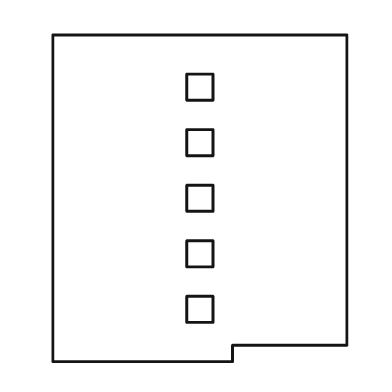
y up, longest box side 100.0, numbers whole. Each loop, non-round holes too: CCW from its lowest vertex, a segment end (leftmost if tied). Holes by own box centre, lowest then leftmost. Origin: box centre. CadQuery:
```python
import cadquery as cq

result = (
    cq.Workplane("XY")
    .moveTo(-45.0, -50.0)
    .lineTo(10.0, -50.0)
    .lineTo(10.0, -45.0)
    .lineTo(45.0, -45.0)
    .lineTo(45.0, 50.0)
    .lineTo(-45.0, 50.0)
    .close()
    .moveTo(-4.0, -38.0)
    .lineTo(4.0, -38.0)
    .lineTo(4.0, -30.0)
    .lineTo(-4.0, -30.0)
    .close()
    .moveTo(-4.0, -21.0)
    .lineTo(4.0, -21.0)
    .lineTo(4.0, -13.0)
    .lineTo(-4.0, -13.0)
    .close()
    .moveTo(-4.0, -4.0)
    .lineTo(4.0, -4.0)
    .lineTo(4.0, 4.0)
    .lineTo(-4.0, 4.0)
    .close()
    .moveTo(-4.0, 13.0)
    .lineTo(4.0, 13.0)
    .lineTo(4.0, 21.0)
    .lineTo(-4.0, 21.0)
    .close()
    .moveTo(-4.0, 30.0)
    .lineTo(4.0, 30.0)
    .lineTo(4.0, 38.0)
    .lineTo(-4.0, 38.0)
    .close()
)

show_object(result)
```